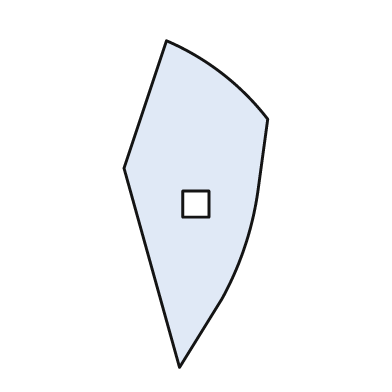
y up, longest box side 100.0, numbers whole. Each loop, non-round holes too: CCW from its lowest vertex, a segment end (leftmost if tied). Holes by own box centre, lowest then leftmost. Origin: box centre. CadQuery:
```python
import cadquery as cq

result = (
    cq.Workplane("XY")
    .moveTo(-5.0, -50.0)
    .lineTo(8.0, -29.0)
    .threePointArc((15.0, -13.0), (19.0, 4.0))
    .lineTo(22.0, 26.0)
    .threePointArc((8.0, 40.0), (-9.0, 50.0))
    .lineTo(-22.0, 11.0)
    .close()
    .moveTo(-4.0, -4.0)
    .lineTo(4.0, -4.0)
    .lineTo(4.0, 4.0)
    .lineTo(-4.0, 4.0)
    .close()
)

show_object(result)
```